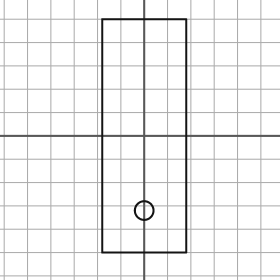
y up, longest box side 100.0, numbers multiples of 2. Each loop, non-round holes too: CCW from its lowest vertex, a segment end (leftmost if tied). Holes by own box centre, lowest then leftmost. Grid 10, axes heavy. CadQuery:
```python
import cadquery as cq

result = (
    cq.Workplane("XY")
    .moveTo(-18.0, -50.0)
    .lineTo(18.0, -50.0)
    .lineTo(18.0, 50.0)
    .lineTo(-18.0, 50.0)
    .close()
    .moveTo(0.0, -32.0)
    .circle(4.0)
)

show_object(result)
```